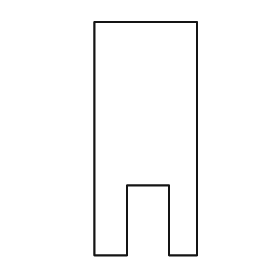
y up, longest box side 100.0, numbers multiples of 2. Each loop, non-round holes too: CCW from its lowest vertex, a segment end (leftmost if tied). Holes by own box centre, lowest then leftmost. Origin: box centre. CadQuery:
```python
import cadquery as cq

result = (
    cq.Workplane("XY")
    .moveTo(-22.0, -50.0)
    .lineTo(-8.0, -50.0)
    .lineTo(-8.0, -20.0)
    .lineTo(10.0, -20.0)
    .lineTo(10.0, -50.0)
    .lineTo(22.0, -50.0)
    .lineTo(22.0, 50.0)
    .lineTo(-22.0, 50.0)
    .close()
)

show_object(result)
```